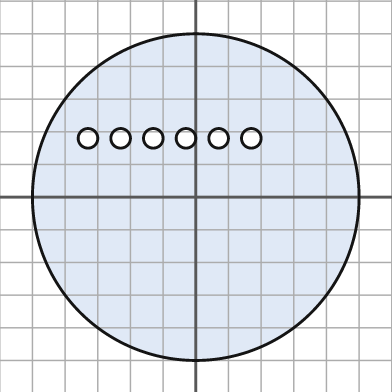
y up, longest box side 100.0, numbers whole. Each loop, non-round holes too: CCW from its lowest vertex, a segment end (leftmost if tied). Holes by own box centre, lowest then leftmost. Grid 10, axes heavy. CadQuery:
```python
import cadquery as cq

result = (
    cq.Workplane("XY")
    .moveTo(0.0, 0.0)
    .circle(50.0)
    .moveTo(-33.0, 18.0)
    .circle(3.0)
    .moveTo(-23.0, 18.0)
    .circle(3.0)
    .moveTo(-13.0, 18.0)
    .circle(3.0)
    .moveTo(-3.0, 18.0)
    .circle(3.0)
    .moveTo(7.0, 18.0)
    .circle(3.0)
    .moveTo(17.0, 18.0)
    .circle(3.0)
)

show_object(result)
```